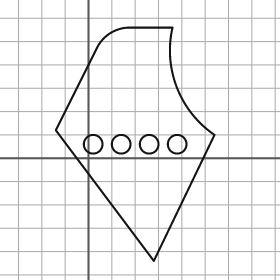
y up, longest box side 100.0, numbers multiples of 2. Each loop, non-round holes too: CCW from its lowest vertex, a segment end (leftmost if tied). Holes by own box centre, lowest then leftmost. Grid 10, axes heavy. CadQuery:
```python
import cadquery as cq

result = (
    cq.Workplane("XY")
    .moveTo(28.0, -44.0)
    .lineTo(54.0, 10.0)
    .threePointArc((38.0, 30.0), (36.0, 56.0))
    .lineTo(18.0, 56.0)
    .threePointArc((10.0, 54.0), (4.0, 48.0))
    .lineTo(-14.0, 12.0)
    .close()
    .moveTo(2.0, 6.0)
    .circle(4.0)
    .moveTo(14.0, 6.0)
    .circle(4.0)
    .moveTo(26.0, 6.0)
    .circle(4.0)
    .moveTo(38.0, 6.0)
    .circle(4.0)
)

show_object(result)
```